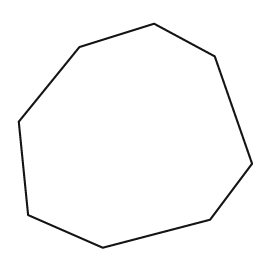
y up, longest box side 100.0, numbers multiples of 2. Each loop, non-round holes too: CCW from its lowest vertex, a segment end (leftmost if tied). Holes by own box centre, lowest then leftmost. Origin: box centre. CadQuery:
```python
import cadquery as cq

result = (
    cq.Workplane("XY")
    .moveTo(-14.0, -48.0)
    .lineTo(32.0, -36.0)
    .lineTo(50.0, -12.0)
    .lineTo(34.0, 34.0)
    .lineTo(8.0, 48.0)
    .lineTo(-24.0, 38.0)
    .lineTo(-50.0, 6.0)
    .lineTo(-46.0, -34.0)
    .close()
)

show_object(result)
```